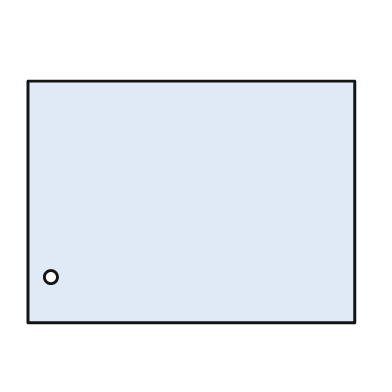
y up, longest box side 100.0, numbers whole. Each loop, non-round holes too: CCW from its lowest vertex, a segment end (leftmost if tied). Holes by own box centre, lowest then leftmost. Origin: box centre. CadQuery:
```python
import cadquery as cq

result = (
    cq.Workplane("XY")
    .moveTo(-50.0, -37.0)
    .lineTo(50.0, -37.0)
    .lineTo(50.0, 37.0)
    .lineTo(-50.0, 37.0)
    .close()
    .moveTo(-43.0, -23.0)
    .circle(2.0)
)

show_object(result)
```